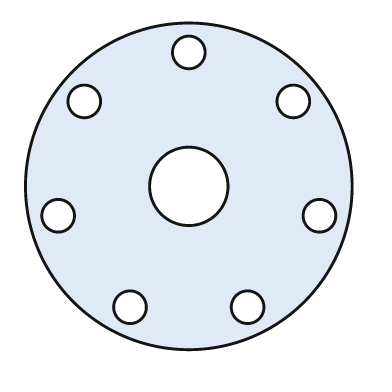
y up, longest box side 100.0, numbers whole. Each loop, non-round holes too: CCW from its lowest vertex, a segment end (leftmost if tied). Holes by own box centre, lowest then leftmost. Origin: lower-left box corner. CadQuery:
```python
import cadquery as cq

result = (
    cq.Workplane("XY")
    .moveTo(50.0, 50.0)
    .circle(50.0)
    .moveTo(32.0, 13.0)
    .circle(5.0)
    .moveTo(68.0, 13.0)
    .circle(5.0)
    .moveTo(10.0, 41.0)
    .circle(5.0)
    .moveTo(90.0, 41.0)
    .circle(5.0)
    .moveTo(50.0, 50.0)
    .circle(12.0)
    .moveTo(18.0, 76.0)
    .circle(5.0)
    .moveTo(82.0, 76.0)
    .circle(5.0)
    .moveTo(50.0, 91.0)
    .circle(5.0)
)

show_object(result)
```